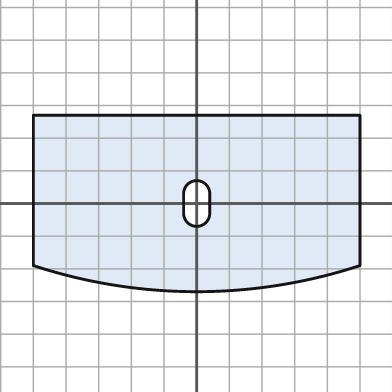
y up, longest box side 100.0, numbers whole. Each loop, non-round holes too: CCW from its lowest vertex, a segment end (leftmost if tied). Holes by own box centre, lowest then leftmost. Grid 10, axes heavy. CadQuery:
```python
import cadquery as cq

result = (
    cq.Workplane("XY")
    .moveTo(-50.0, -19.0)
    .threePointArc((0.0, -27.0), (50.0, -19.0))
    .lineTo(50.0, 27.0)
    .lineTo(-50.0, 27.0)
    .close()
    .moveTo(-4.0, -3.0)
    .threePointArc((0.0, -7.0), (4.0, -3.0))
    .lineTo(4.0, 3.0)
    .threePointArc((0.0, 7.0), (-4.0, 3.0))
    .close()
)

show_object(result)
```